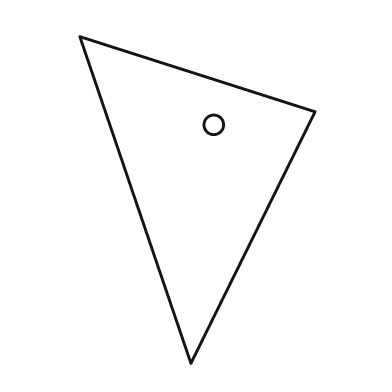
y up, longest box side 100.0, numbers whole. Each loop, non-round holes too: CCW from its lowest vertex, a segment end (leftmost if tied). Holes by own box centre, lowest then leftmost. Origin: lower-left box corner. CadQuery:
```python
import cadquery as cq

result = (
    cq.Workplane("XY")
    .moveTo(34.0, 0.0)
    .lineTo(72.0, 77.0)
    .lineTo(0.0, 100.0)
    .close()
    .moveTo(41.0, 73.0)
    .circle(3.0)
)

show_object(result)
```